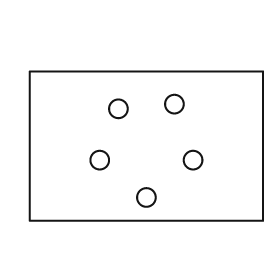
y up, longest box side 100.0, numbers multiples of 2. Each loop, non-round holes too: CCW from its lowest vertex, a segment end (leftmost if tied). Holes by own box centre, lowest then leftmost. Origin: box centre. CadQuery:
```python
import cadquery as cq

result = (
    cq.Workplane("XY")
    .moveTo(-50.0, -32.0)
    .lineTo(50.0, -32.0)
    .lineTo(50.0, 32.0)
    .lineTo(-50.0, 32.0)
    .close()
    .moveTo(0.0, -22.0)
    .circle(4.0)
    .moveTo(-20.0, -6.0)
    .circle(4.0)
    .moveTo(20.0, -6.0)
    .circle(4.0)
    .moveTo(-12.0, 16.0)
    .circle(4.0)
    .moveTo(12.0, 18.0)
    .circle(4.0)
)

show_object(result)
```